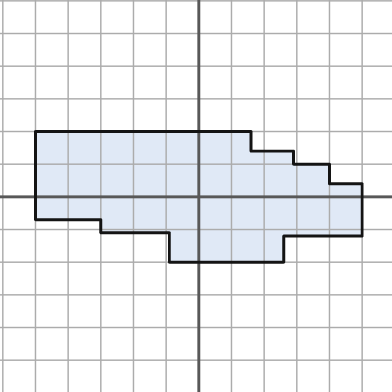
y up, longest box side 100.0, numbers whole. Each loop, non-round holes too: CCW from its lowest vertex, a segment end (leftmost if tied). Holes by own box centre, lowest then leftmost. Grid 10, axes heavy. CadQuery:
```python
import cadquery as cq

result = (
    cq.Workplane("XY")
    .moveTo(-9.0, -20.0)
    .lineTo(26.0, -20.0)
    .lineTo(26.0, -12.0)
    .lineTo(50.0, -12.0)
    .lineTo(50.0, 4.0)
    .lineTo(40.0, 4.0)
    .lineTo(40.0, 10.0)
    .lineTo(29.0, 10.0)
    .lineTo(29.0, 14.0)
    .lineTo(16.0, 14.0)
    .lineTo(16.0, 20.0)
    .lineTo(-50.0, 20.0)
    .lineTo(-50.0, -7.0)
    .lineTo(-30.0, -7.0)
    .lineTo(-30.0, -11.0)
    .lineTo(-9.0, -11.0)
    .close()
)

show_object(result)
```